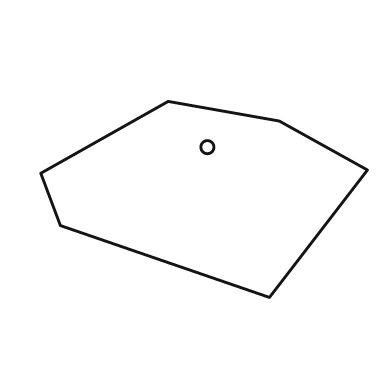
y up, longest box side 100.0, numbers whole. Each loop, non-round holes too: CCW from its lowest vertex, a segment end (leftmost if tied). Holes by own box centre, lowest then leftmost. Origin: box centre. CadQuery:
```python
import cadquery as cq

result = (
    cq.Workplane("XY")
    .moveTo(20.0, -30.0)
    .lineTo(50.0, 9.0)
    .lineTo(23.0, 24.0)
    .lineTo(-11.0, 30.0)
    .lineTo(-50.0, 8.0)
    .lineTo(-44.0, -8.0)
    .close()
    .moveTo(1.0, 16.0)
    .circle(2.0)
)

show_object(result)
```